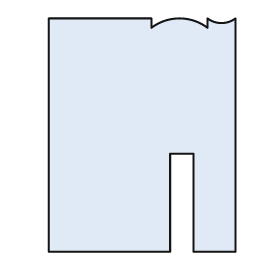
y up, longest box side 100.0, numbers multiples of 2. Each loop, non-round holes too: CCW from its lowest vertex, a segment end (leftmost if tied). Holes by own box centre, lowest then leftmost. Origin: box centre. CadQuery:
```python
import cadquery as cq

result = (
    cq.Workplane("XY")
    .moveTo(-40.0, -50.0)
    .lineTo(12.0, -50.0)
    .lineTo(12.0, -8.0)
    .lineTo(22.0, -8.0)
    .lineTo(22.0, -50.0)
    .lineTo(40.0, -50.0)
    .lineTo(40.0, 50.0)
    .threePointArc((34.0, 48.0), (28.0, 50.0))
    .lineTo(28.0, 46.0)
    .threePointArc((16.0, 50.0), (4.0, 46.0))
    .lineTo(4.0, 50.0)
    .lineTo(-40.0, 50.0)
    .close()
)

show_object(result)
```